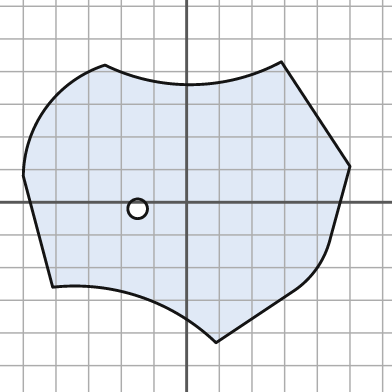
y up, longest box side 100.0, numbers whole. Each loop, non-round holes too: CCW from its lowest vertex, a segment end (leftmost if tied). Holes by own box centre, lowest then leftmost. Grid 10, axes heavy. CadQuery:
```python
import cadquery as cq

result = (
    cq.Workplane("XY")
    .moveTo(9.0, -43.0)
    .lineTo(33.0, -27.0)
    .threePointArc((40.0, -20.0), (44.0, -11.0))
    .lineTo(50.0, 11.0)
    .lineTo(29.0, 43.0)
    .threePointArc((2.0, 36.0), (-25.0, 42.0))
    .threePointArc((-43.0, 29.0), (-50.0, 8.0))
    .lineTo(-41.0, -26.0)
    .threePointArc((-14.0, -29.0), (9.0, -43.0))
    .close()
    .moveTo(-15.0, -2.0)
    .circle(3.0)
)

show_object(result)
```